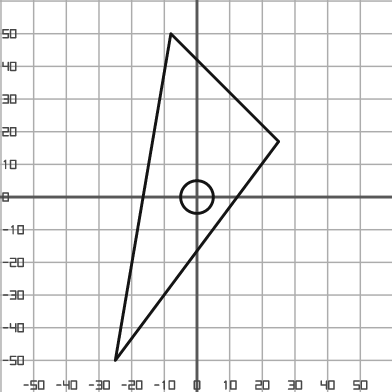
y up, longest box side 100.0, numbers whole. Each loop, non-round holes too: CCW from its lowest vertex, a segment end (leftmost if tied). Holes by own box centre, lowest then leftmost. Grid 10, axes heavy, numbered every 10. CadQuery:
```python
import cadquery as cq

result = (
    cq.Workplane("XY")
    .moveTo(-25.0, -50.0)
    .lineTo(25.0, 17.0)
    .lineTo(-8.0, 50.0)
    .close()
    .moveTo(0.0, 0.0)
    .circle(5.0)
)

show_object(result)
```